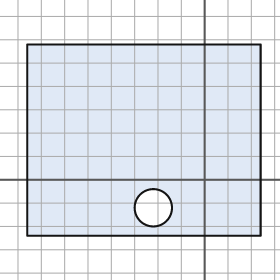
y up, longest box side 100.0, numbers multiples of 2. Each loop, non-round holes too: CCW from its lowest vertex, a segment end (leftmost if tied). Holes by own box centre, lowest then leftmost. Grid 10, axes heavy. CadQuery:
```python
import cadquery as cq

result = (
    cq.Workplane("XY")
    .moveTo(-76.0, -24.0)
    .lineTo(24.0, -24.0)
    .lineTo(24.0, 58.0)
    .lineTo(-76.0, 58.0)
    .close()
    .moveTo(-22.0, -12.0)
    .circle(8.0)
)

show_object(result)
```